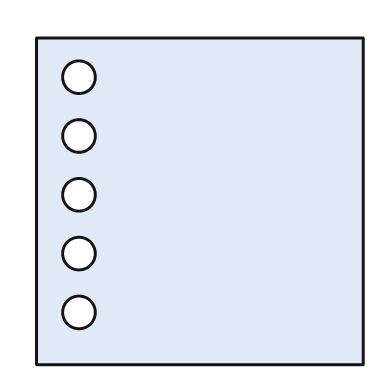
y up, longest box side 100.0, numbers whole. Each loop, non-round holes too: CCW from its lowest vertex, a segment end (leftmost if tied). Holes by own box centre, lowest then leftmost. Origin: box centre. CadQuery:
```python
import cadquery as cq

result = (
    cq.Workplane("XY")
    .moveTo(-50.0, -50.0)
    .lineTo(50.0, -50.0)
    .lineTo(50.0, 50.0)
    .lineTo(-50.0, 50.0)
    .close()
    .moveTo(-37.0, -34.0)
    .circle(5.0)
    .moveTo(-37.0, -16.0)
    .circle(5.0)
    .moveTo(-37.0, 2.0)
    .circle(5.0)
    .moveTo(-37.0, 20.0)
    .circle(5.0)
    .moveTo(-37.0, 38.0)
    .circle(5.0)
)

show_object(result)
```